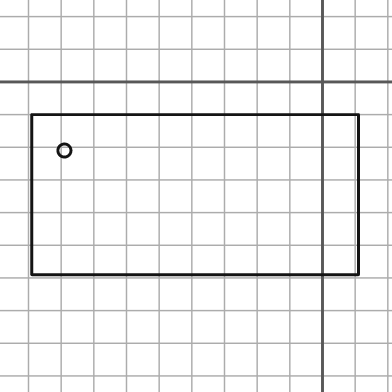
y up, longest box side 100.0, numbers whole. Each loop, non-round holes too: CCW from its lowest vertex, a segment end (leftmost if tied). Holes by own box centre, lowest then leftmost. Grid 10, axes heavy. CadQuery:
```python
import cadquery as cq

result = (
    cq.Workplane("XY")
    .moveTo(-89.0, -59.0)
    .lineTo(11.0, -59.0)
    .lineTo(11.0, -10.0)
    .lineTo(-89.0, -10.0)
    .close()
    .moveTo(-79.0, -21.0)
    .circle(2.0)
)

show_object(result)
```